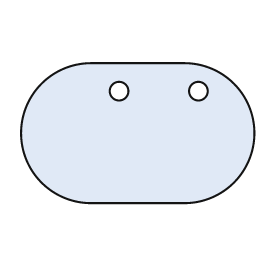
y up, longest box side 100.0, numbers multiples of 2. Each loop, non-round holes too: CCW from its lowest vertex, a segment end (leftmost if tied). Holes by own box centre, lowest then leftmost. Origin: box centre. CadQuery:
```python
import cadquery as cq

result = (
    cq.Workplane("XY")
    .moveTo(-20.0, -30.0)
    .lineTo(20.0, -30.0)
    .threePointArc((50.0, 0.0), (20.0, 30.0))
    .lineTo(-20.0, 30.0)
    .threePointArc((-50.0, 0.0), (-20.0, -30.0))
    .close()
    .moveTo(-8.0, 18.0)
    .circle(4.0)
    .moveTo(26.0, 18.0)
    .circle(4.0)
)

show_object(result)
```